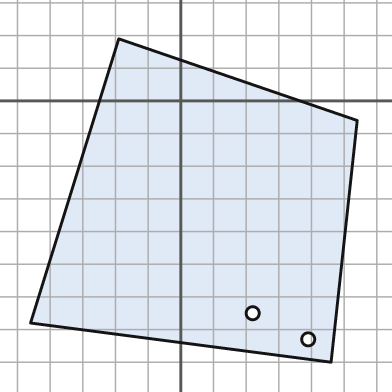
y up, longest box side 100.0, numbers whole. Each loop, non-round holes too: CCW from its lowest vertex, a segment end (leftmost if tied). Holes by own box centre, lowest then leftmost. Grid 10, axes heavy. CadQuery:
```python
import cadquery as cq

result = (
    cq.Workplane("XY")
    .moveTo(46.0, -80.0)
    .lineTo(54.0, -6.0)
    .lineTo(-19.0, 19.0)
    .lineTo(-46.0, -68.0)
    .close()
    .moveTo(39.0, -73.0)
    .circle(2.0)
    .moveTo(22.0, -65.0)
    .circle(2.0)
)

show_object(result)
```